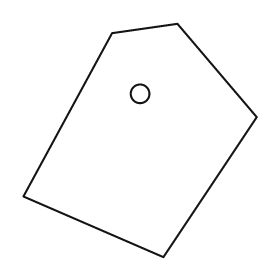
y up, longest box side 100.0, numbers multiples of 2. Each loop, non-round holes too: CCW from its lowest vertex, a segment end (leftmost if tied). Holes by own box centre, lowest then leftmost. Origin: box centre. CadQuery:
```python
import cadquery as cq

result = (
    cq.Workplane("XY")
    .moveTo(10.0, -50.0)
    .lineTo(50.0, 10.0)
    .lineTo(16.0, 50.0)
    .lineTo(-12.0, 46.0)
    .lineTo(-50.0, -24.0)
    .close()
    .moveTo(0.0, 20.0)
    .circle(4.0)
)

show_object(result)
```